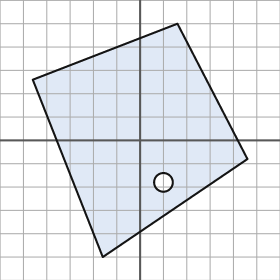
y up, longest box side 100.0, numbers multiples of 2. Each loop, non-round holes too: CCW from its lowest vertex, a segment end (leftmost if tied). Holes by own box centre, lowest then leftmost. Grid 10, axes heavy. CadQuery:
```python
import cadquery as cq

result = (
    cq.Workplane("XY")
    .moveTo(-16.0, -50.0)
    .lineTo(46.0, -8.0)
    .lineTo(16.0, 50.0)
    .lineTo(-46.0, 26.0)
    .close()
    .moveTo(10.0, -18.0)
    .circle(4.0)
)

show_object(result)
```